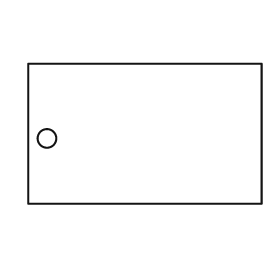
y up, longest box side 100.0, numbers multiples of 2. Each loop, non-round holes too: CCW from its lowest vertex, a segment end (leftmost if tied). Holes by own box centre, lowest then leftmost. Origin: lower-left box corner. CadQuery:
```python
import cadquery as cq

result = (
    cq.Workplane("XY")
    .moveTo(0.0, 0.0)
    .lineTo(100.0, 0.0)
    .lineTo(100.0, 60.0)
    .lineTo(0.0, 60.0)
    .close()
    .moveTo(8.0, 28.0)
    .circle(4.0)
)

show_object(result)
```